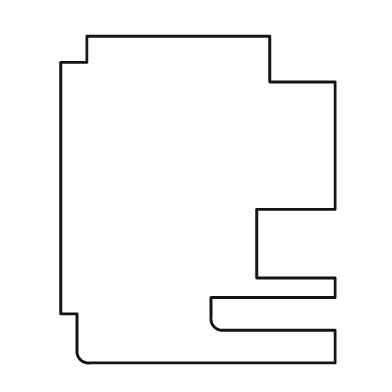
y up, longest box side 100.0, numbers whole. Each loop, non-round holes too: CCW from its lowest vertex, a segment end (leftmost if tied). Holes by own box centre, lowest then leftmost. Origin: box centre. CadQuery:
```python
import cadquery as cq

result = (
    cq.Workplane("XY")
    .moveTo(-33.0, -50.0)
    .lineTo(42.0, -50.0)
    .lineTo(42.0, -40.0)
    .lineTo(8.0, -40.0)
    .threePointArc((5.0, -39.0), (4.0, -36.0))
    .lineTo(4.0, -30.0)
    .lineTo(42.0, -30.0)
    .lineTo(42.0, -24.0)
    .lineTo(18.0, -24.0)
    .lineTo(18.0, -3.0)
    .lineTo(42.0, -3.0)
    .lineTo(42.0, 36.0)
    .lineTo(22.0, 36.0)
    .lineTo(22.0, 50.0)
    .lineTo(-34.0, 50.0)
    .lineTo(-34.0, 42.0)
    .lineTo(-42.0, 42.0)
    .lineTo(-42.0, -35.0)
    .lineTo(-37.0, -35.0)
    .lineTo(-37.0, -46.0)
    .threePointArc((-36.0, -49.0), (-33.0, -50.0))
    .close()
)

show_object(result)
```